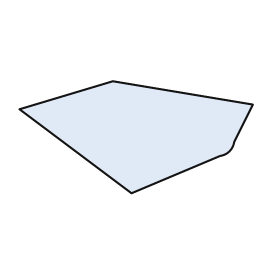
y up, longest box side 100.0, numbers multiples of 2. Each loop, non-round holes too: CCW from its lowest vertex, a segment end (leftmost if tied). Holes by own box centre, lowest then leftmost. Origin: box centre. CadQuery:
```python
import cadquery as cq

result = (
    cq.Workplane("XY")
    .moveTo(-2.0, -24.0)
    .lineTo(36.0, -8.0)
    .threePointArc((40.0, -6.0), (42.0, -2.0))
    .lineTo(50.0, 14.0)
    .lineTo(-10.0, 24.0)
    .lineTo(-50.0, 12.0)
    .close()
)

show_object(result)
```